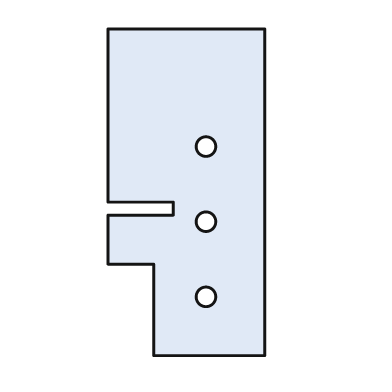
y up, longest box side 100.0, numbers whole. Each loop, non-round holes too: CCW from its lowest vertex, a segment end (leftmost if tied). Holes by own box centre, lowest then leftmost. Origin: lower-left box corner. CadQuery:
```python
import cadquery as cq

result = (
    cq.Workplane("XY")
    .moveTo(14.0, 0.0)
    .lineTo(48.0, 0.0)
    .lineTo(48.0, 100.0)
    .lineTo(0.0, 100.0)
    .lineTo(0.0, 47.0)
    .lineTo(20.0, 47.0)
    .lineTo(20.0, 43.0)
    .lineTo(0.0, 43.0)
    .lineTo(0.0, 28.0)
    .lineTo(14.0, 28.0)
    .close()
    .moveTo(30.0, 18.0)
    .circle(3.0)
    .moveTo(30.0, 41.0)
    .circle(3.0)
    .moveTo(30.0, 64.0)
    .circle(3.0)
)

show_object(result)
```